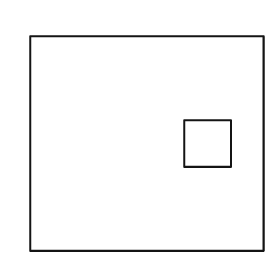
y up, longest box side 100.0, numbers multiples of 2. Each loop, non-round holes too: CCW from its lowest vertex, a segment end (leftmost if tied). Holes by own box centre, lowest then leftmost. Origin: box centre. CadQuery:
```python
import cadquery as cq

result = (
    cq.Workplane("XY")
    .moveTo(-50.0, -46.0)
    .lineTo(50.0, -46.0)
    .lineTo(50.0, 46.0)
    .lineTo(-50.0, 46.0)
    .close()
    .moveTo(16.0, -10.0)
    .lineTo(36.0, -10.0)
    .lineTo(36.0, 10.0)
    .lineTo(16.0, 10.0)
    .close()
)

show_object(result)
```